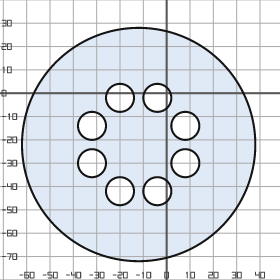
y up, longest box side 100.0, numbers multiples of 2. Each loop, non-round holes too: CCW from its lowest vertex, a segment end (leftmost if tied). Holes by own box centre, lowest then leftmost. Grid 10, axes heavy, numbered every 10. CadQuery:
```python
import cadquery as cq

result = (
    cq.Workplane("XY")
    .moveTo(-12.0, -22.0)
    .circle(50.0)
    .moveTo(-20.0, -42.0)
    .circle(6.0)
    .moveTo(-4.0, -42.0)
    .circle(6.0)
    .moveTo(-32.0, -30.0)
    .circle(6.0)
    .moveTo(8.0, -30.0)
    .circle(6.0)
    .moveTo(-32.0, -14.0)
    .circle(6.0)
    .moveTo(8.0, -14.0)
    .circle(6.0)
    .moveTo(-20.0, -2.0)
    .circle(6.0)
    .moveTo(-4.0, -2.0)
    .circle(6.0)
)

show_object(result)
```